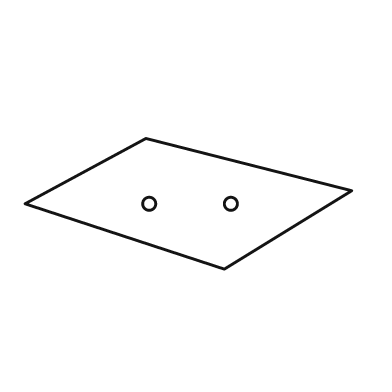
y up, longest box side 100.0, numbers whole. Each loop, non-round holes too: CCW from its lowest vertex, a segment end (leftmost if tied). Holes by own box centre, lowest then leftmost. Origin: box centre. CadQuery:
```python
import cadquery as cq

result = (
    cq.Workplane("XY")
    .moveTo(11.0, -20.0)
    .lineTo(50.0, 4.0)
    .lineTo(-13.0, 20.0)
    .lineTo(-50.0, 0.0)
    .close()
    .moveTo(-12.0, 0.0)
    .circle(2.0)
    .moveTo(13.0, 0.0)
    .circle(2.0)
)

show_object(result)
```